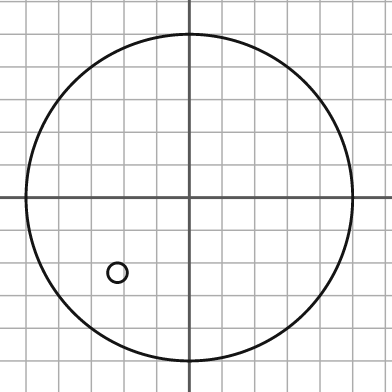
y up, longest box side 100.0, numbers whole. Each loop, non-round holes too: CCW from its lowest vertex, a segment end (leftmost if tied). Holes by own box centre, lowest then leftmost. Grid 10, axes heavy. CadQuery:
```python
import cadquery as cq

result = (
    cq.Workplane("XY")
    .moveTo(0.0, 0.0)
    .circle(50.0)
    .moveTo(-22.0, -23.0)
    .circle(3.0)
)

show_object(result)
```